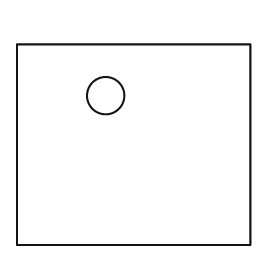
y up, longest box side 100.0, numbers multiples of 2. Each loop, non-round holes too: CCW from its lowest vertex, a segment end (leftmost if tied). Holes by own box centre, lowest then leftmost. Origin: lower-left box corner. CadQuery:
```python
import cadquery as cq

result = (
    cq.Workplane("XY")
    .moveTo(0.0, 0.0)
    .lineTo(100.0, 0.0)
    .lineTo(100.0, 86.0)
    .lineTo(0.0, 86.0)
    .close()
    .moveTo(38.0, 64.0)
    .circle(8.0)
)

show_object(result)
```